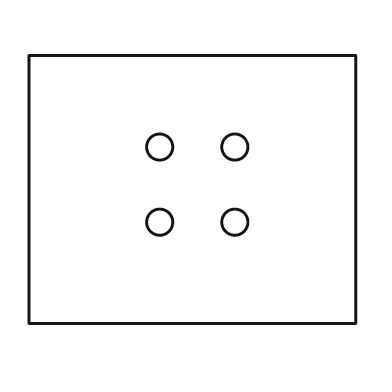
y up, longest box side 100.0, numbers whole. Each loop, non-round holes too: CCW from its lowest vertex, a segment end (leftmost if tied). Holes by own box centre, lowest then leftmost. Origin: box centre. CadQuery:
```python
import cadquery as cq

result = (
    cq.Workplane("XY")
    .moveTo(-50.0, -41.0)
    .lineTo(50.0, -41.0)
    .lineTo(50.0, 41.0)
    .lineTo(-50.0, 41.0)
    .close()
    .moveTo(-10.0, -10.0)
    .circle(4.0)
    .moveTo(13.0, -10.0)
    .circle(4.0)
    .moveTo(-10.0, 13.0)
    .circle(4.0)
    .moveTo(13.0, 13.0)
    .circle(4.0)
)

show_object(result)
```